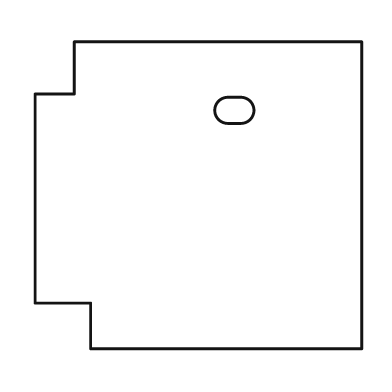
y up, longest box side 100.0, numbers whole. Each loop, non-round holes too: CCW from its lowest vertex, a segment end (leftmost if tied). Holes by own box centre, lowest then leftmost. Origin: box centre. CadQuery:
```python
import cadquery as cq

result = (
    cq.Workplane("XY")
    .moveTo(-33.0, -47.0)
    .lineTo(50.0, -47.0)
    .lineTo(50.0, 47.0)
    .lineTo(-38.0, 47.0)
    .lineTo(-38.0, 31.0)
    .lineTo(-50.0, 31.0)
    .lineTo(-50.0, -33.0)
    .lineTo(-33.0, -33.0)
    .close()
    .moveTo(9.0, 22.0)
    .lineTo(13.0, 22.0)
    .threePointArc((17.0, 26.0), (13.0, 30.0))
    .lineTo(9.0, 30.0)
    .threePointArc((5.0, 26.0), (9.0, 22.0))
    .close()
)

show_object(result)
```